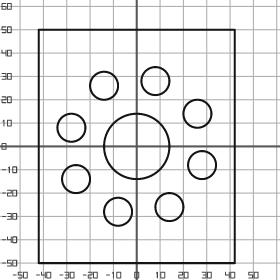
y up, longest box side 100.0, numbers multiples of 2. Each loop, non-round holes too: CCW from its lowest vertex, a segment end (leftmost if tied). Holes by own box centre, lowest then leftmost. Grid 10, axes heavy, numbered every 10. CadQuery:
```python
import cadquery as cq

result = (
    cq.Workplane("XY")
    .moveTo(-42.0, -50.0)
    .lineTo(42.0, -50.0)
    .lineTo(42.0, 50.0)
    .lineTo(-42.0, 50.0)
    .close()
    .moveTo(-8.0, -28.0)
    .circle(6.0)
    .moveTo(14.0, -26.0)
    .circle(6.0)
    .moveTo(-26.0, -14.0)
    .circle(6.0)
    .moveTo(28.0, -8.0)
    .circle(6.0)
    .moveTo(0.0, 0.0)
    .circle(14.0)
    .moveTo(-28.0, 8.0)
    .circle(6.0)
    .moveTo(26.0, 14.0)
    .circle(6.0)
    .moveTo(-14.0, 26.0)
    .circle(6.0)
    .moveTo(8.0, 28.0)
    .circle(6.0)
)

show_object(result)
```